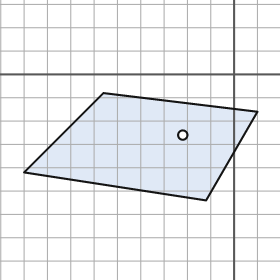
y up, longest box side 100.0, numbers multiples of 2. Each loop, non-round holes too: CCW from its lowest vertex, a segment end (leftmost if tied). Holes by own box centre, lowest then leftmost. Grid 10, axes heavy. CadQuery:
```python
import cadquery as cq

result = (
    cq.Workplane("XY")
    .moveTo(-12.0, -54.0)
    .lineTo(10.0, -16.0)
    .lineTo(-56.0, -8.0)
    .lineTo(-90.0, -42.0)
    .close()
    .moveTo(-22.0, -26.0)
    .circle(2.0)
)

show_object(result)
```